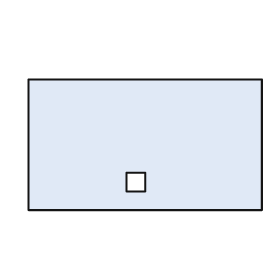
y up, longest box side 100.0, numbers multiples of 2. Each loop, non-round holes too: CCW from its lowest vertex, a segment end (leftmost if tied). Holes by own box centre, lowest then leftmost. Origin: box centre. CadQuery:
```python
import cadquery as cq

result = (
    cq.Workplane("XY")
    .moveTo(-50.0, -28.0)
    .lineTo(50.0, -28.0)
    .lineTo(50.0, 28.0)
    .lineTo(-50.0, 28.0)
    .close()
    .moveTo(-8.0, -20.0)
    .lineTo(0.0, -20.0)
    .lineTo(0.0, -12.0)
    .lineTo(-8.0, -12.0)
    .close()
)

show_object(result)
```